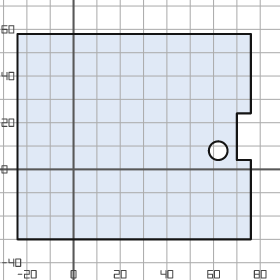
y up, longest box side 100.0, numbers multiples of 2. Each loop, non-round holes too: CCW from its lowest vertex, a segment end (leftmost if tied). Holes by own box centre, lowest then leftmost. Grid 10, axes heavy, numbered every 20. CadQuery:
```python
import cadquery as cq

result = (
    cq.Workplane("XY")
    .moveTo(-24.0, -30.0)
    .lineTo(76.0, -30.0)
    .lineTo(76.0, 4.0)
    .lineTo(70.0, 4.0)
    .lineTo(70.0, 24.0)
    .lineTo(76.0, 24.0)
    .lineTo(76.0, 58.0)
    .lineTo(-24.0, 58.0)
    .close()
    .moveTo(62.0, 8.0)
    .circle(4.0)
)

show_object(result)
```